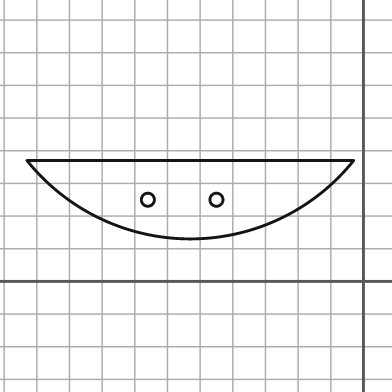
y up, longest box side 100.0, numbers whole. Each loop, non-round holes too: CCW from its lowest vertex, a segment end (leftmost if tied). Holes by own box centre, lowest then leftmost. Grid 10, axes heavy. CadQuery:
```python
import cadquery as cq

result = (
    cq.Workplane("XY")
    .moveTo(-103.0, 37.0)
    .threePointArc((-53.0, 13.0), (-3.0, 37.0))
    .close()
    .moveTo(-66.0, 25.0)
    .circle(2.0)
    .moveTo(-45.0, 25.0)
    .circle(2.0)
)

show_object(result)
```